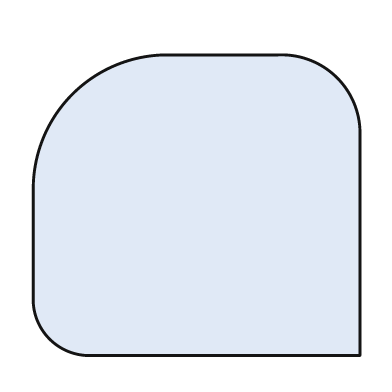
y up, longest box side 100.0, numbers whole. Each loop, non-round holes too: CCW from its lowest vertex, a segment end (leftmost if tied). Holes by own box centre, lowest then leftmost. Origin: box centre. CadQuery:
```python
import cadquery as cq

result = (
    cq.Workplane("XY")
    .moveTo(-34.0, -46.0)
    .lineTo(50.0, -46.0)
    .lineTo(50.0, 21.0)
    .threePointArc((43.0, 39.0), (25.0, 46.0))
    .lineTo(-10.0, 46.0)
    .threePointArc((-38.0, 34.0), (-50.0, 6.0))
    .lineTo(-50.0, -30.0)
    .threePointArc((-45.0, -41.0), (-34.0, -46.0))
    .close()
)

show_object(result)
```